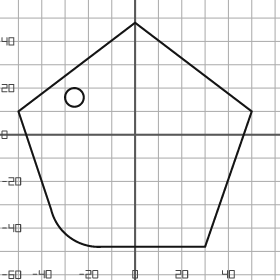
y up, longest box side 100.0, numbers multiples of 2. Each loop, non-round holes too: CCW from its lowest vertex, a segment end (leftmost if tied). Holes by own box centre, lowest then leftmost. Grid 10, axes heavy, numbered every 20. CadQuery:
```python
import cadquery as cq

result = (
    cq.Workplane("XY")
    .moveTo(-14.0, -48.0)
    .lineTo(30.0, -48.0)
    .lineTo(50.0, 10.0)
    .lineTo(0.0, 48.0)
    .lineTo(-50.0, 10.0)
    .lineTo(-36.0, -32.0)
    .threePointArc((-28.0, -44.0), (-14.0, -48.0))
    .close()
    .moveTo(-26.0, 16.0)
    .circle(4.0)
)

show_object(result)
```